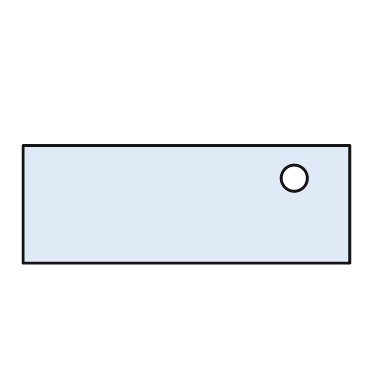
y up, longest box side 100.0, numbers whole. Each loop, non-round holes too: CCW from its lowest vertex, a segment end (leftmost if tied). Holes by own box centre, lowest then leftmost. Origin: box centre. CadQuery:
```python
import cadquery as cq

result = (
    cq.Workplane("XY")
    .moveTo(-50.0, -18.0)
    .lineTo(50.0, -18.0)
    .lineTo(50.0, 18.0)
    .lineTo(-50.0, 18.0)
    .close()
    .moveTo(33.0, 8.0)
    .circle(4.0)
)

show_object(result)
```